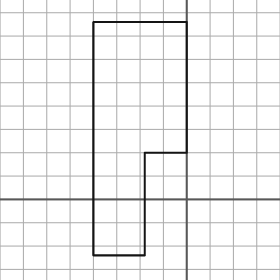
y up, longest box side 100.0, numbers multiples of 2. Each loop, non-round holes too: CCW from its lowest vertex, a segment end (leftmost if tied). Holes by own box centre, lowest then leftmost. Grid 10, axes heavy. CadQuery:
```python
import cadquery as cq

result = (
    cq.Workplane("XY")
    .moveTo(-40.0, -24.0)
    .lineTo(-18.0, -24.0)
    .lineTo(-18.0, 20.0)
    .lineTo(0.0, 20.0)
    .lineTo(0.0, 76.0)
    .lineTo(-40.0, 76.0)
    .close()
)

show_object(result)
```